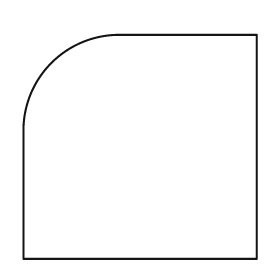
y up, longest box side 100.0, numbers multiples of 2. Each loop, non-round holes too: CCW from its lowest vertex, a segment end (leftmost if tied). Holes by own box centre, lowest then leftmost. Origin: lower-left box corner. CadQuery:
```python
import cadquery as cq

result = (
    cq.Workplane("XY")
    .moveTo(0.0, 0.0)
    .lineTo(100.0, 0.0)
    .lineTo(100.0, 96.0)
    .lineTo(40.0, 96.0)
    .threePointArc((12.0, 84.0), (0.0, 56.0))
    .close()
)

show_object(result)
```